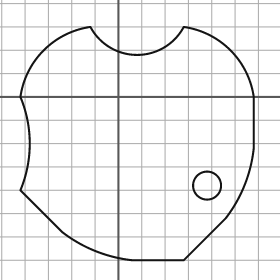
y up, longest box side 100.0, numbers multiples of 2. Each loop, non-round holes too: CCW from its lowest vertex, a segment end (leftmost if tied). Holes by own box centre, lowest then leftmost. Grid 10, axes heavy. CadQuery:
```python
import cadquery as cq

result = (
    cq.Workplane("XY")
    .moveTo(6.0, -70.0)
    .lineTo(28.0, -70.0)
    .lineTo(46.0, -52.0)
    .threePointArc((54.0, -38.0), (58.0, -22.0))
    .lineTo(58.0, 0.0)
    .threePointArc((48.0, 20.0), (28.0, 30.0))
    .threePointArc((8.0, 18.0), (-12.0, 30.0))
    .threePointArc((-32.0, 20.0), (-42.0, 0.0))
    .threePointArc((-38.0, -20.0), (-42.0, -40.0))
    .lineTo(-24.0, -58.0)
    .threePointArc((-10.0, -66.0), (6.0, -70.0))
    .close()
    .moveTo(38.0, -38.0)
    .circle(6.0)
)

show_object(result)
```